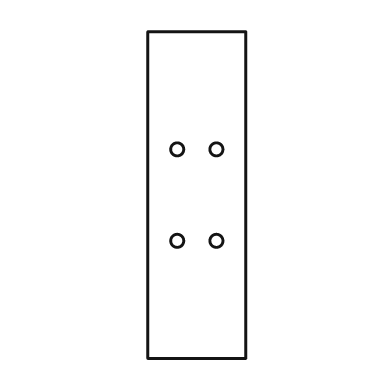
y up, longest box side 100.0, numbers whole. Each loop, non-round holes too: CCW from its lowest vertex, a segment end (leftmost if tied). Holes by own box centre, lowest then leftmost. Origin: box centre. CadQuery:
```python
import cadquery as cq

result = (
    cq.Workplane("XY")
    .moveTo(-15.0, -50.0)
    .lineTo(15.0, -50.0)
    .lineTo(15.0, 50.0)
    .lineTo(-15.0, 50.0)
    .close()
    .moveTo(-6.0, -14.0)
    .circle(2.0)
    .moveTo(6.0, -14.0)
    .circle(2.0)
    .moveTo(-6.0, 14.0)
    .circle(2.0)
    .moveTo(6.0, 14.0)
    .circle(2.0)
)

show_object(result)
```